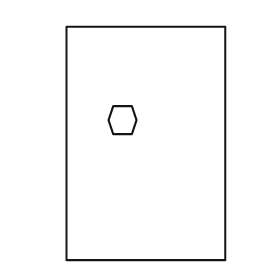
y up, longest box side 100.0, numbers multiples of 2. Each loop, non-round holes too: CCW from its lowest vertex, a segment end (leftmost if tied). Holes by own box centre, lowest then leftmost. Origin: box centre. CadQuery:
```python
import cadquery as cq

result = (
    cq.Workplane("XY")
    .moveTo(-34.0, -50.0)
    .lineTo(34.0, -50.0)
    .lineTo(34.0, 50.0)
    .lineTo(-34.0, 50.0)
    .close()
    .moveTo(-14.0, 4.0)
    .lineTo(-6.0, 4.0)
    .lineTo(-4.0, 10.0)
    .lineTo(-6.0, 16.0)
    .lineTo(-14.0, 16.0)
    .lineTo(-16.0, 10.0)
    .close()
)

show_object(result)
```